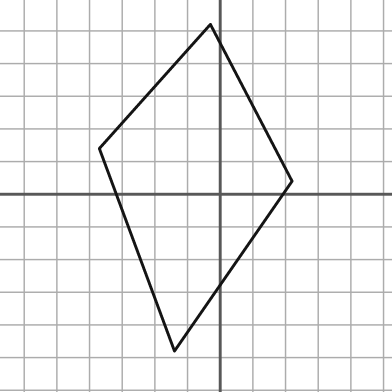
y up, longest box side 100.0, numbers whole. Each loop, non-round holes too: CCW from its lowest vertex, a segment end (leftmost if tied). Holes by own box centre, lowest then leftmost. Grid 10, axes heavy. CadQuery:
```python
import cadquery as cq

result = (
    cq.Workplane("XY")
    .moveTo(-14.0, -48.0)
    .lineTo(22.0, 4.0)
    .lineTo(-3.0, 52.0)
    .lineTo(-37.0, 14.0)
    .close()
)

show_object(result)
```